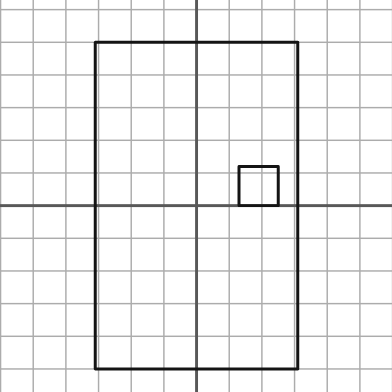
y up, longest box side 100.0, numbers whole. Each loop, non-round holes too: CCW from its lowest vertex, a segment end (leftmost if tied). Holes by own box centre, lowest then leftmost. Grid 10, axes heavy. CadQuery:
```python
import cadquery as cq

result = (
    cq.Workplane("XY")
    .moveTo(-31.0, -50.0)
    .lineTo(31.0, -50.0)
    .lineTo(31.0, 50.0)
    .lineTo(-31.0, 50.0)
    .close()
    .moveTo(13.0, 0.0)
    .lineTo(25.0, 0.0)
    .lineTo(25.0, 12.0)
    .lineTo(13.0, 12.0)
    .close()
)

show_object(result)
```